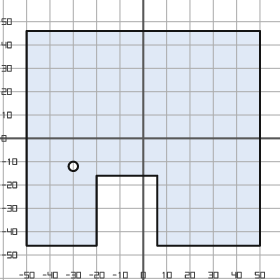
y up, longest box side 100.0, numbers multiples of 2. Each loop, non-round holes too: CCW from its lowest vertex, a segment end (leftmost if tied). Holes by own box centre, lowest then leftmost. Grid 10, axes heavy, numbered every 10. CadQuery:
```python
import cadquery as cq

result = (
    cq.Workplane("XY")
    .moveTo(-50.0, -46.0)
    .lineTo(-20.0, -46.0)
    .lineTo(-20.0, -16.0)
    .lineTo(6.0, -16.0)
    .lineTo(6.0, -46.0)
    .lineTo(50.0, -46.0)
    .lineTo(50.0, 46.0)
    .lineTo(-50.0, 46.0)
    .close()
    .moveTo(-30.0, -12.0)
    .circle(2.0)
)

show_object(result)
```